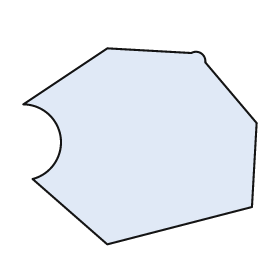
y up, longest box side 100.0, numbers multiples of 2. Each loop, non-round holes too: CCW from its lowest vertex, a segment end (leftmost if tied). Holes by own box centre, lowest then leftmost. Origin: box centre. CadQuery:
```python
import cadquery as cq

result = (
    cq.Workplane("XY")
    .moveTo(-14.0, -42.0)
    .lineTo(48.0, -26.0)
    .lineTo(50.0, 10.0)
    .lineTo(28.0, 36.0)
    .threePointArc((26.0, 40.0), (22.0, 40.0))
    .lineTo(-14.0, 42.0)
    .lineTo(-50.0, 18.0)
    .threePointArc((-34.0, 4.0), (-46.0, -14.0))
    .close()
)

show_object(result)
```